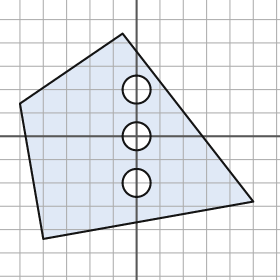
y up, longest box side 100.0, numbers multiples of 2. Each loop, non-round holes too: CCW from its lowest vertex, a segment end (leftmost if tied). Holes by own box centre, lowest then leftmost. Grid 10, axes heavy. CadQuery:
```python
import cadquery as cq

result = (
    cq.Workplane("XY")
    .moveTo(-40.0, -44.0)
    .lineTo(50.0, -28.0)
    .lineTo(-6.0, 44.0)
    .lineTo(-50.0, 14.0)
    .close()
    .moveTo(0.0, -20.0)
    .circle(6.0)
    .moveTo(0.0, 0.0)
    .circle(6.0)
    .moveTo(0.0, 20.0)
    .circle(6.0)
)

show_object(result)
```